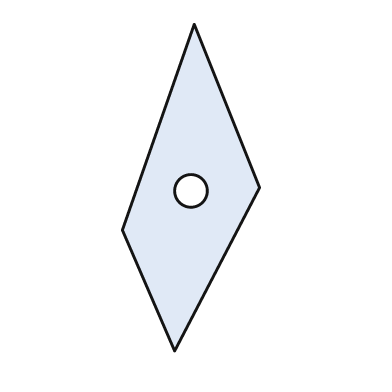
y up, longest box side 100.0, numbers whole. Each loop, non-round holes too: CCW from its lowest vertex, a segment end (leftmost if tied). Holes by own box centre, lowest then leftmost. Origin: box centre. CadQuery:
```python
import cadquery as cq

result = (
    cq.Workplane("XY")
    .moveTo(-5.0, -50.0)
    .lineTo(21.0, 0.0)
    .lineTo(1.0, 50.0)
    .lineTo(-21.0, -13.0)
    .close()
    .moveTo(0.0, -1.0)
    .circle(5.0)
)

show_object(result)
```